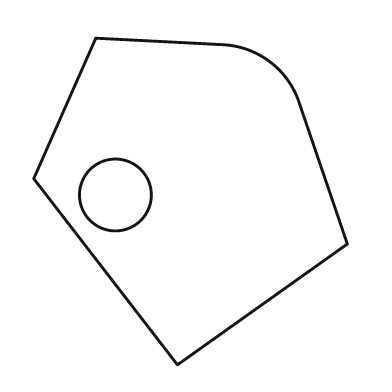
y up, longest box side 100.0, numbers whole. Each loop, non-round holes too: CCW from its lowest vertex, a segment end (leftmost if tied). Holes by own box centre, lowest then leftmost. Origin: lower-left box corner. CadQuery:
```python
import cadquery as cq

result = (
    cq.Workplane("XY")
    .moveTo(44.0, 0.0)
    .lineTo(96.0, 37.0)
    .lineTo(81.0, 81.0)
    .threePointArc((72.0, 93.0), (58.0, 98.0))
    .lineTo(19.0, 100.0)
    .lineTo(0.0, 57.0)
    .close()
    .moveTo(25.0, 52.0)
    .circle(11.0)
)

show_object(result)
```